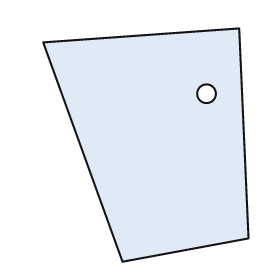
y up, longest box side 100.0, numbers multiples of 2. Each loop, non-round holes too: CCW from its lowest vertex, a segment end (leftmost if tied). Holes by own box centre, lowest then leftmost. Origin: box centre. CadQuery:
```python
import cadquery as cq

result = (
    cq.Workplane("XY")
    .moveTo(-10.0, -50.0)
    .lineTo(44.0, -40.0)
    .lineTo(40.0, 50.0)
    .lineTo(-44.0, 44.0)
    .close()
    .moveTo(26.0, 22.0)
    .circle(4.0)
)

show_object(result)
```